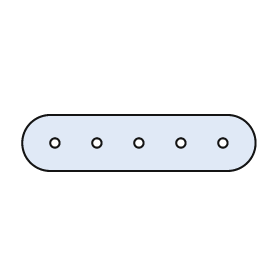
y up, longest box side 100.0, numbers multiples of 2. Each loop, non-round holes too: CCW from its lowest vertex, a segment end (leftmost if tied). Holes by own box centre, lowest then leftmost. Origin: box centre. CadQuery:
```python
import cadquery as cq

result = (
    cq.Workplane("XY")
    .moveTo(-38.0, -12.0)
    .lineTo(38.0, -12.0)
    .threePointArc((50.0, 0.0), (38.0, 12.0))
    .lineTo(-38.0, 12.0)
    .threePointArc((-50.0, 0.0), (-38.0, -12.0))
    .close()
    .moveTo(-36.0, 0.0)
    .circle(2.0)
    .moveTo(-18.0, 0.0)
    .circle(2.0)
    .moveTo(0.0, 0.0)
    .circle(2.0)
    .moveTo(18.0, 0.0)
    .circle(2.0)
    .moveTo(36.0, 0.0)
    .circle(2.0)
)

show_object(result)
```